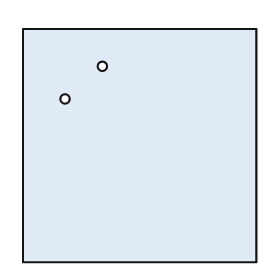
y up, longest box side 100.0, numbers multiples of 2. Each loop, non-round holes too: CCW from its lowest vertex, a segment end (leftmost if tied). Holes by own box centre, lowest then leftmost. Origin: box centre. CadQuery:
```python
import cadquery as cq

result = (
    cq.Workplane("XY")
    .moveTo(-50.0, -50.0)
    .lineTo(50.0, -50.0)
    .lineTo(50.0, 50.0)
    .lineTo(-50.0, 50.0)
    .close()
    .moveTo(-32.0, 20.0)
    .circle(2.0)
    .moveTo(-16.0, 34.0)
    .circle(2.0)
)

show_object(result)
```